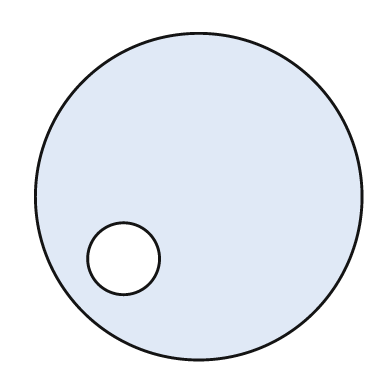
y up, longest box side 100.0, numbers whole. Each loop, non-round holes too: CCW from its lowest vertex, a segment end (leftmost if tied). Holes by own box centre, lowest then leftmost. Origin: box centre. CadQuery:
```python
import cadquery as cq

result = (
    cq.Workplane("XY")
    .moveTo(0.0, 0.0)
    .circle(50.0)
    .moveTo(-23.0, -19.0)
    .circle(11.0)
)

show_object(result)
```